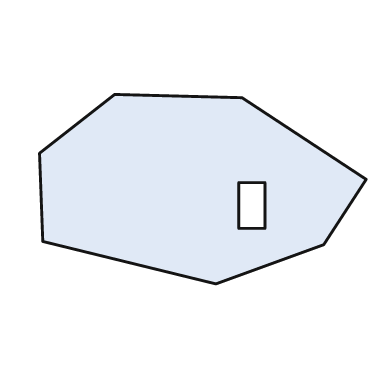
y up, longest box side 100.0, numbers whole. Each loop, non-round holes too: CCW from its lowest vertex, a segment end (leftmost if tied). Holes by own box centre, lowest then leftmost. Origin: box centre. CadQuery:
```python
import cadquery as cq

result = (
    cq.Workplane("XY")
    .moveTo(4.0, -29.0)
    .lineTo(37.0, -17.0)
    .lineTo(50.0, 3.0)
    .lineTo(12.0, 28.0)
    .lineTo(-27.0, 29.0)
    .lineTo(-50.0, 11.0)
    .lineTo(-49.0, -16.0)
    .close()
    .moveTo(11.0, -12.0)
    .lineTo(19.0, -12.0)
    .lineTo(19.0, 2.0)
    .lineTo(11.0, 2.0)
    .close()
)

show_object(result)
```